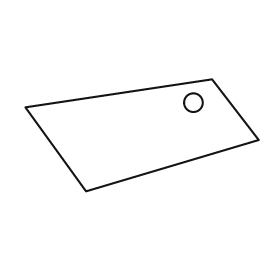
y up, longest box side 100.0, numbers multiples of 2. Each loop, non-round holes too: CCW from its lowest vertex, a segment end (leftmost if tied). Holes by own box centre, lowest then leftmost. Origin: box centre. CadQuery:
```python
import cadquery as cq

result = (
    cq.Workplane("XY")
    .moveTo(-24.0, -24.0)
    .lineTo(50.0, -2.0)
    .lineTo(30.0, 24.0)
    .lineTo(-50.0, 12.0)
    .close()
    .moveTo(22.0, 14.0)
    .circle(4.0)
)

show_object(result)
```